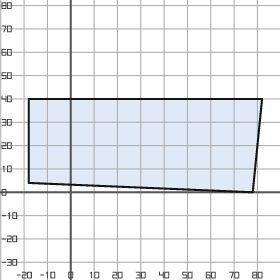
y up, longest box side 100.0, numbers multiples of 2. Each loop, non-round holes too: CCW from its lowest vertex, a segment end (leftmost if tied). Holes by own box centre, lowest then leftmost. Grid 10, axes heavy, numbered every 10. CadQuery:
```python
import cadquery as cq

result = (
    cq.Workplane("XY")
    .moveTo(78.0, 0.0)
    .lineTo(82.0, 40.0)
    .lineTo(-18.0, 40.0)
    .lineTo(-18.0, 4.0)
    .close()
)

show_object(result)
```